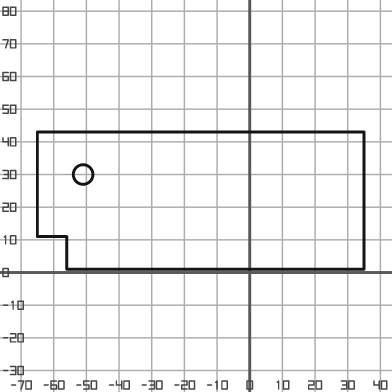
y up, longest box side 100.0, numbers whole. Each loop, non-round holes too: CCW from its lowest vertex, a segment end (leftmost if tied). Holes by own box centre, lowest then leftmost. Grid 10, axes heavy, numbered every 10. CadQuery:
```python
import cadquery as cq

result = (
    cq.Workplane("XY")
    .moveTo(-56.0, 1.0)
    .lineTo(35.0, 1.0)
    .lineTo(35.0, 43.0)
    .lineTo(-65.0, 43.0)
    .lineTo(-65.0, 11.0)
    .lineTo(-56.0, 11.0)
    .close()
    .moveTo(-51.0, 30.0)
    .circle(3.0)
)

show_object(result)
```